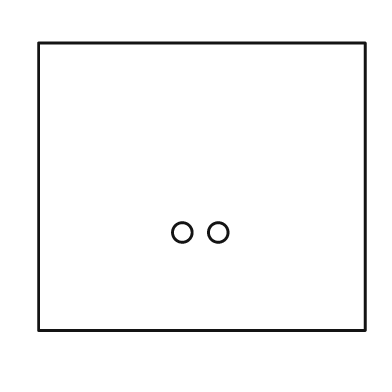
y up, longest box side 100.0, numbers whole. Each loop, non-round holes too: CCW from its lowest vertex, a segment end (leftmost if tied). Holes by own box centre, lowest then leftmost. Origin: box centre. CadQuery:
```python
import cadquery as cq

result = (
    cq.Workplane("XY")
    .moveTo(-50.0, -44.0)
    .lineTo(50.0, -44.0)
    .lineTo(50.0, 44.0)
    .lineTo(-50.0, 44.0)
    .close()
    .moveTo(-6.0, -14.0)
    .circle(3.0)
    .moveTo(5.0, -14.0)
    .circle(3.0)
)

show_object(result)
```